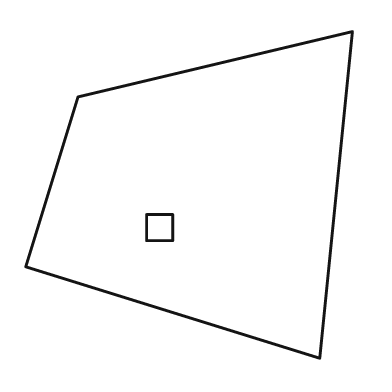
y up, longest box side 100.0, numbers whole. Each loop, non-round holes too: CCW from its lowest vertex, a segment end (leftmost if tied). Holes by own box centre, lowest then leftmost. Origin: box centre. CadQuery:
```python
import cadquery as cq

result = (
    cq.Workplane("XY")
    .moveTo(40.0, -50.0)
    .lineTo(50.0, 50.0)
    .lineTo(-34.0, 30.0)
    .lineTo(-50.0, -22.0)
    .close()
    .moveTo(-13.0, -14.0)
    .lineTo(-5.0, -14.0)
    .lineTo(-5.0, -6.0)
    .lineTo(-13.0, -6.0)
    .close()
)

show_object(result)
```